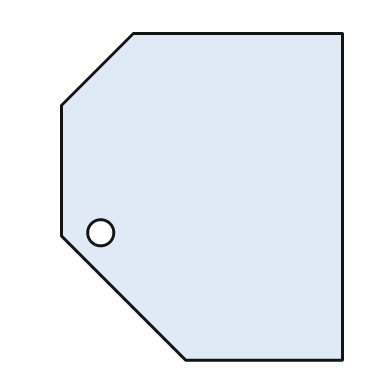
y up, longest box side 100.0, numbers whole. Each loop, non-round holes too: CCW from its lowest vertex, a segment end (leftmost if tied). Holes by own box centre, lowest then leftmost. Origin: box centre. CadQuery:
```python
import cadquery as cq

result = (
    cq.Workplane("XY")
    .moveTo(-5.0, -50.0)
    .lineTo(43.0, -50.0)
    .lineTo(43.0, 50.0)
    .lineTo(-21.0, 50.0)
    .lineTo(-43.0, 28.0)
    .lineTo(-43.0, -12.0)
    .close()
    .moveTo(-31.0, -11.0)
    .circle(4.0)
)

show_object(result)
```